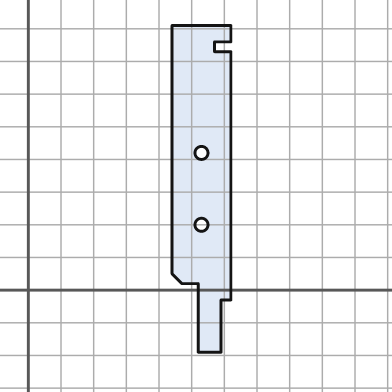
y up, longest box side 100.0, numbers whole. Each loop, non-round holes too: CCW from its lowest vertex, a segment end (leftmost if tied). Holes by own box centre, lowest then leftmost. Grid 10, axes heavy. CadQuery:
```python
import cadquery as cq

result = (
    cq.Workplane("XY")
    .moveTo(52.0, -19.0)
    .lineTo(59.0, -19.0)
    .lineTo(59.0, -3.0)
    .lineTo(62.0, -3.0)
    .lineTo(62.0, 73.0)
    .lineTo(57.0, 73.0)
    .lineTo(57.0, 76.0)
    .lineTo(62.0, 76.0)
    .lineTo(62.0, 81.0)
    .lineTo(44.0, 81.0)
    .lineTo(44.0, 5.0)
    .lineTo(47.0, 2.0)
    .lineTo(52.0, 2.0)
    .close()
    .moveTo(53.0, 20.0)
    .circle(2.0)
    .moveTo(53.0, 42.0)
    .circle(2.0)
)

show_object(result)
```